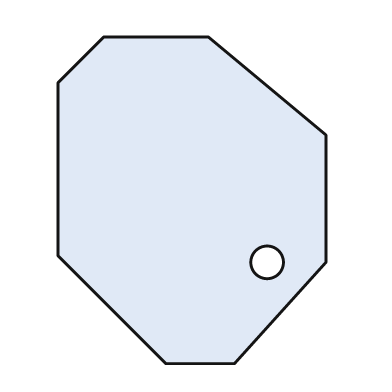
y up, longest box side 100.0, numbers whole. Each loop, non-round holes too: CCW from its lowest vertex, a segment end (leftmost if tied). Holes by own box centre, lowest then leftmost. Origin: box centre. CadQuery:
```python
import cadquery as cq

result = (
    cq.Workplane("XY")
    .moveTo(-8.0, -50.0)
    .lineTo(13.0, -50.0)
    .lineTo(41.0, -19.0)
    .lineTo(41.0, 20.0)
    .lineTo(5.0, 50.0)
    .lineTo(-27.0, 50.0)
    .lineTo(-41.0, 36.0)
    .lineTo(-41.0, -17.0)
    .close()
    .moveTo(23.0, -19.0)
    .circle(5.0)
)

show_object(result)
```